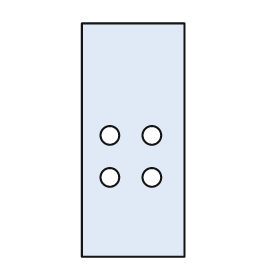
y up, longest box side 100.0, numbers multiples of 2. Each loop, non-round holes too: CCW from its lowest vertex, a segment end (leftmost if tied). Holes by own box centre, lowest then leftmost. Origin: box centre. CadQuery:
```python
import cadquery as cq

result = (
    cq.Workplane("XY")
    .moveTo(-22.0, -50.0)
    .lineTo(22.0, -50.0)
    .lineTo(22.0, 50.0)
    .lineTo(-22.0, 50.0)
    .close()
    .moveTo(-10.0, -16.0)
    .circle(4.0)
    .moveTo(8.0, -16.0)
    .circle(4.0)
    .moveTo(-10.0, 2.0)
    .circle(4.0)
    .moveTo(8.0, 2.0)
    .circle(4.0)
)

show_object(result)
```